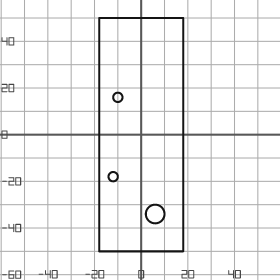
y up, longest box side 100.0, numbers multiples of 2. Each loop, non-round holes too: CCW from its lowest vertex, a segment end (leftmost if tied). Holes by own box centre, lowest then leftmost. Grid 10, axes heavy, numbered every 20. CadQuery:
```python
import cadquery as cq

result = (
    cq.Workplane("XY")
    .moveTo(-18.0, -50.0)
    .lineTo(18.0, -50.0)
    .lineTo(18.0, 50.0)
    .lineTo(-18.0, 50.0)
    .close()
    .moveTo(6.0, -34.0)
    .circle(4.0)
    .moveTo(-12.0, -18.0)
    .circle(2.0)
    .moveTo(-10.0, 16.0)
    .circle(2.0)
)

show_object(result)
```